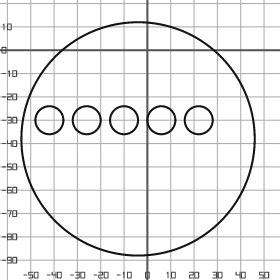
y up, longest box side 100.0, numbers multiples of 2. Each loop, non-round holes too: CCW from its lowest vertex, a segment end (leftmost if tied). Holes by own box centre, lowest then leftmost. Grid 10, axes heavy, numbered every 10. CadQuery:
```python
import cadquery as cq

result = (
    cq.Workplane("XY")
    .moveTo(-4.0, -38.0)
    .circle(50.0)
    .moveTo(-42.0, -30.0)
    .circle(6.0)
    .moveTo(-26.0, -30.0)
    .circle(6.0)
    .moveTo(-10.0, -30.0)
    .circle(6.0)
    .moveTo(6.0, -30.0)
    .circle(6.0)
    .moveTo(22.0, -30.0)
    .circle(6.0)
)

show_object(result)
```